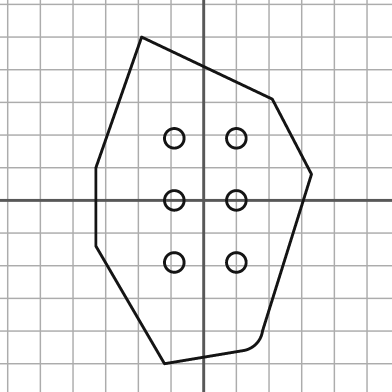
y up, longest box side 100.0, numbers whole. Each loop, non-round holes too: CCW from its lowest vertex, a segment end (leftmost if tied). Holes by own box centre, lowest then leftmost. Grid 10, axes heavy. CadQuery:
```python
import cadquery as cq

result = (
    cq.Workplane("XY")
    .moveTo(-12.0, -50.0)
    .lineTo(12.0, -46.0)
    .threePointArc((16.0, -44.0), (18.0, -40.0))
    .lineTo(33.0, 8.0)
    .lineTo(21.0, 31.0)
    .lineTo(-19.0, 50.0)
    .lineTo(-33.0, 10.0)
    .lineTo(-33.0, -14.0)
    .close()
    .moveTo(-9.0, -19.0)
    .circle(3.0)
    .moveTo(10.0, -19.0)
    .circle(3.0)
    .moveTo(-9.0, 0.0)
    .circle(3.0)
    .moveTo(10.0, 0.0)
    .circle(3.0)
    .moveTo(-9.0, 19.0)
    .circle(3.0)
    .moveTo(10.0, 19.0)
    .circle(3.0)
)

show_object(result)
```